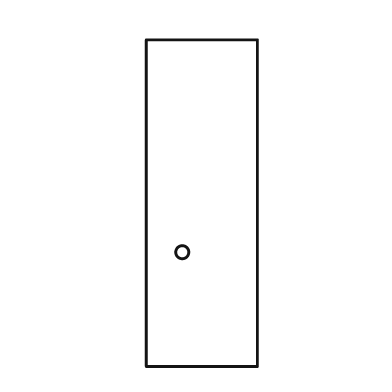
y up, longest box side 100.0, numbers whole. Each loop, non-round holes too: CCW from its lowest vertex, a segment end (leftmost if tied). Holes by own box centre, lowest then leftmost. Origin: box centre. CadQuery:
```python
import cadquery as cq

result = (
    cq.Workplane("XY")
    .moveTo(-17.0, -50.0)
    .lineTo(17.0, -50.0)
    .lineTo(17.0, 50.0)
    .lineTo(-17.0, 50.0)
    .close()
    .moveTo(-6.0, -15.0)
    .circle(2.0)
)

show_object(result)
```